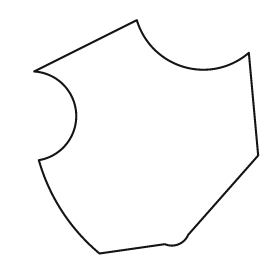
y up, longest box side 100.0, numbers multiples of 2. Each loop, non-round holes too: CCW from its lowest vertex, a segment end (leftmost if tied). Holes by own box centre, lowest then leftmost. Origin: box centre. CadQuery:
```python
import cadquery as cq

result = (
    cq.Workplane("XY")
    .moveTo(-20.0, -50.0)
    .lineTo(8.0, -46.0)
    .threePointArc((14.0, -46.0), (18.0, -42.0))
    .lineTo(48.0, -8.0)
    .lineTo(44.0, 36.0)
    .threePointArc((16.0, 30.0), (-4.0, 50.0))
    .lineTo(-48.0, 28.0)
    .threePointArc((-30.0, 10.0), (-46.0, -10.0))
    .threePointArc((-36.0, -32.0), (-20.0, -50.0))
    .close()
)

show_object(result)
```